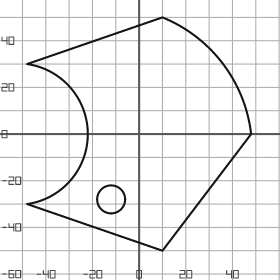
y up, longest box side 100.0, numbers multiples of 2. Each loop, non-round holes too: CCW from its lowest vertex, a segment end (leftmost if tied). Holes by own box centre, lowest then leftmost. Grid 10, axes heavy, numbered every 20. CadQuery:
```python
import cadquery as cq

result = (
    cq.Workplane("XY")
    .moveTo(10.0, -50.0)
    .lineTo(48.0, 0.0)
    .threePointArc((36.0, 30.0), (10.0, 50.0))
    .lineTo(-48.0, 30.0)
    .threePointArc((-22.0, 0.0), (-48.0, -30.0))
    .close()
    .moveTo(-12.0, -28.0)
    .circle(6.0)
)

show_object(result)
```